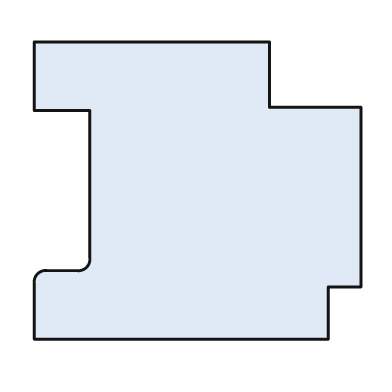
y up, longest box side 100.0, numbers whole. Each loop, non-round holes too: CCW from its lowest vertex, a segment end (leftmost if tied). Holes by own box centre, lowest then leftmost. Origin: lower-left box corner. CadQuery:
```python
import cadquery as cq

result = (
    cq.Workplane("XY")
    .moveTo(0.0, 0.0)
    .lineTo(90.0, 0.0)
    .lineTo(90.0, 16.0)
    .lineTo(100.0, 16.0)
    .lineTo(100.0, 71.0)
    .lineTo(72.0, 71.0)
    .lineTo(72.0, 91.0)
    .lineTo(0.0, 91.0)
    .lineTo(0.0, 70.0)
    .lineTo(17.0, 70.0)
    .lineTo(17.0, 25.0)
    .threePointArc((16.0, 22.0), (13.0, 21.0))
    .lineTo(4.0, 21.0)
    .threePointArc((1.0, 20.0), (0.0, 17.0))
    .close()
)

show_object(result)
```